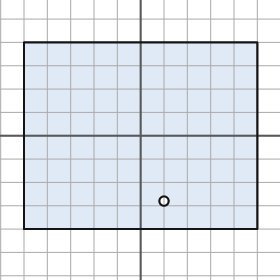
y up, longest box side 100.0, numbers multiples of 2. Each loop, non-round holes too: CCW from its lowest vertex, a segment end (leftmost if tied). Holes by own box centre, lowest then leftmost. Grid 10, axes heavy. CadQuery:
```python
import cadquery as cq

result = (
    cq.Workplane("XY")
    .moveTo(-50.0, -40.0)
    .lineTo(50.0, -40.0)
    .lineTo(50.0, 40.0)
    .lineTo(-50.0, 40.0)
    .close()
    .moveTo(10.0, -28.0)
    .circle(2.0)
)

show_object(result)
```